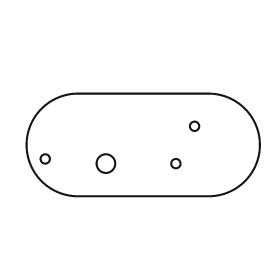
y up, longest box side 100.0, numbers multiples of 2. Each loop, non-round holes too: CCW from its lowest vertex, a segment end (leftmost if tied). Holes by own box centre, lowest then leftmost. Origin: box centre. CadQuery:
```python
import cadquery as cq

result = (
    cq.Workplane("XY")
    .moveTo(-28.0, -22.0)
    .lineTo(28.0, -22.0)
    .threePointArc((50.0, 0.0), (28.0, 22.0))
    .lineTo(-28.0, 22.0)
    .threePointArc((-50.0, 0.0), (-28.0, -22.0))
    .close()
    .moveTo(-16.0, -8.0)
    .circle(4.0)
    .moveTo(14.0, -8.0)
    .circle(2.0)
    .moveTo(-42.0, -6.0)
    .circle(2.0)
    .moveTo(22.0, 8.0)
    .circle(2.0)
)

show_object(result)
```